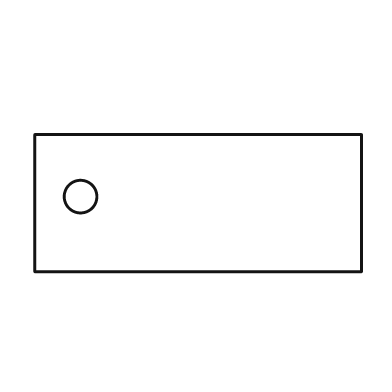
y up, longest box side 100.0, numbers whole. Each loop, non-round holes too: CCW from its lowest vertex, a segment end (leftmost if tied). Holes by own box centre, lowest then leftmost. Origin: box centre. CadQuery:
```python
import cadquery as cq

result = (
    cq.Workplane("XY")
    .moveTo(-50.0, -21.0)
    .lineTo(50.0, -21.0)
    .lineTo(50.0, 21.0)
    .lineTo(-50.0, 21.0)
    .close()
    .moveTo(-36.0, 2.0)
    .circle(5.0)
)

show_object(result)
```